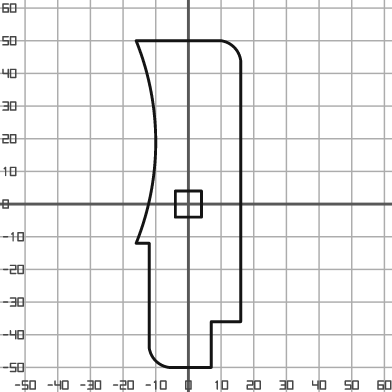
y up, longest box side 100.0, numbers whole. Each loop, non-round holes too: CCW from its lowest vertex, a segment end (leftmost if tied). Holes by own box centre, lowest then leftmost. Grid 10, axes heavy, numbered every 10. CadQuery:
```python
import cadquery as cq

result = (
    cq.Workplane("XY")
    .moveTo(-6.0, -50.0)
    .lineTo(7.0, -50.0)
    .lineTo(7.0, -36.0)
    .lineTo(16.0, -36.0)
    .lineTo(16.0, 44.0)
    .threePointArc((14.0, 48.0), (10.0, 50.0))
    .lineTo(-16.0, 50.0)
    .threePointArc((-10.0, 19.0), (-16.0, -12.0))
    .lineTo(-12.0, -12.0)
    .lineTo(-12.0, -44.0)
    .threePointArc((-10.0, -48.0), (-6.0, -50.0))
    .close()
    .moveTo(-4.0, -4.0)
    .lineTo(4.0, -4.0)
    .lineTo(4.0, 4.0)
    .lineTo(-4.0, 4.0)
    .close()
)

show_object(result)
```